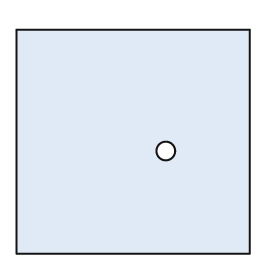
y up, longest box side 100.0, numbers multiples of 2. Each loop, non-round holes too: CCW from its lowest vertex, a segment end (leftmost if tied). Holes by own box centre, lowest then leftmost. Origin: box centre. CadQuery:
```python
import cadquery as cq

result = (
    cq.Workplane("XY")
    .moveTo(-50.0, -48.0)
    .lineTo(50.0, -48.0)
    .lineTo(50.0, 48.0)
    .lineTo(-50.0, 48.0)
    .close()
    .moveTo(14.0, -4.0)
    .circle(4.0)
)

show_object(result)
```